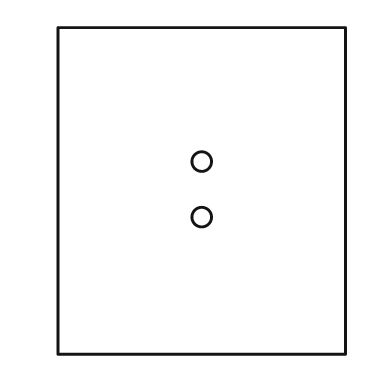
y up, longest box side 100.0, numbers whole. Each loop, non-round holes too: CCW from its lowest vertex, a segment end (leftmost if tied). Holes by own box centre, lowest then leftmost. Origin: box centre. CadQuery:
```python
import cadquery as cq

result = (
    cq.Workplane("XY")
    .moveTo(-44.0, -50.0)
    .lineTo(44.0, -50.0)
    .lineTo(44.0, 50.0)
    .lineTo(-44.0, 50.0)
    .close()
    .moveTo(0.0, -8.0)
    .circle(3.0)
    .moveTo(0.0, 9.0)
    .circle(3.0)
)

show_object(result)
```